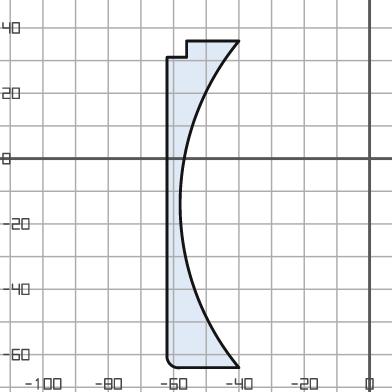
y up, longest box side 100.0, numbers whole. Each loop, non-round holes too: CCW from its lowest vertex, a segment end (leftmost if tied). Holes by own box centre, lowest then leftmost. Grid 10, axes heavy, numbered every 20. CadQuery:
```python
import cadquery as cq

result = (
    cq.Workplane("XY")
    .moveTo(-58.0, -64.0)
    .lineTo(-40.0, -64.0)
    .threePointArc((-58.0, -14.0), (-40.0, 36.0))
    .lineTo(-56.0, 36.0)
    .lineTo(-56.0, 31.0)
    .lineTo(-62.0, 31.0)
    .lineTo(-62.0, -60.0)
    .threePointArc((-61.0, -63.0), (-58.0, -64.0))
    .close()
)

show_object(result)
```